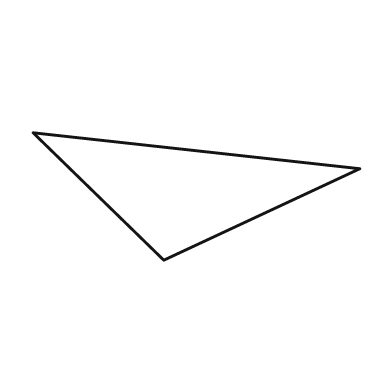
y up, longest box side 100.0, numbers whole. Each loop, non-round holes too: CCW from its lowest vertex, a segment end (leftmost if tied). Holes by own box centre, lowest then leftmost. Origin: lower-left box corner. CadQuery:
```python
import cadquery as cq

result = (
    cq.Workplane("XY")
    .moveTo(40.0, 0.0)
    .lineTo(100.0, 28.0)
    .lineTo(0.0, 39.0)
    .close()
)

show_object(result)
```